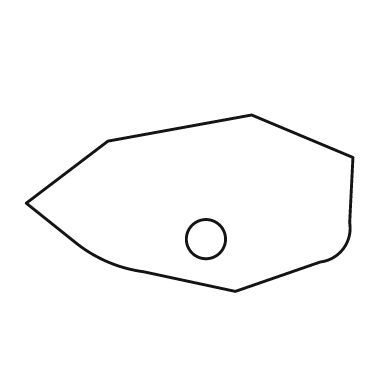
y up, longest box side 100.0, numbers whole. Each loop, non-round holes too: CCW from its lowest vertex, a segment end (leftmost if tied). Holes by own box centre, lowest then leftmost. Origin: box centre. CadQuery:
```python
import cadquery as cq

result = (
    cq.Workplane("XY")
    .moveTo(14.0, -27.0)
    .lineTo(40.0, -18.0)
    .threePointArc((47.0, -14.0), (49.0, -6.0))
    .lineTo(50.0, 14.0)
    .lineTo(19.0, 27.0)
    .lineTo(-25.0, 19.0)
    .lineTo(-50.0, 0.0)
    .lineTo(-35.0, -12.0)
    .threePointArc((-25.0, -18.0), (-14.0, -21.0))
    .close()
    .moveTo(5.0, -11.0)
    .circle(6.0)
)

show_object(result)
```